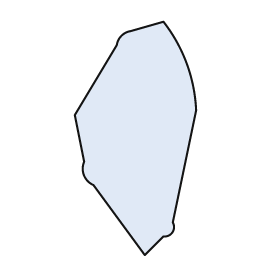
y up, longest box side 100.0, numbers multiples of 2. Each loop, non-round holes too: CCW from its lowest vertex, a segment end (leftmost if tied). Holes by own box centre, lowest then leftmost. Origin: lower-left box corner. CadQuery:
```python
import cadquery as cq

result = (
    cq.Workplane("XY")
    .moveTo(30.0, 0.0)
    .lineTo(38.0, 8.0)
    .threePointArc((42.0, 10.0), (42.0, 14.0))
    .lineTo(52.0, 62.0)
    .threePointArc((48.0, 82.0), (38.0, 100.0))
    .lineTo(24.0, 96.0)
    .threePointArc((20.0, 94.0), (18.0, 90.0))
    .lineTo(0.0, 60.0)
    .lineTo(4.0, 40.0)
    .threePointArc((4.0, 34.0), (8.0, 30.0))
    .close()
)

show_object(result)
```